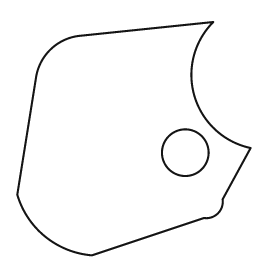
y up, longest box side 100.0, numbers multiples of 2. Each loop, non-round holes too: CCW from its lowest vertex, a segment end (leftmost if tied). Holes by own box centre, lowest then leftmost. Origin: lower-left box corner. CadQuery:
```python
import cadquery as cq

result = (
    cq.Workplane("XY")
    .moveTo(32.0, 0.0)
    .lineTo(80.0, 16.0)
    .threePointArc((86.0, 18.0), (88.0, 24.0))
    .lineTo(100.0, 46.0)
    .threePointArc((76.0, 68.0), (84.0, 100.0))
    .lineTo(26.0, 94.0)
    .threePointArc((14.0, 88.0), (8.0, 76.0))
    .lineTo(0.0, 26.0)
    .threePointArc((12.0, 8.0), (32.0, 0.0))
    .close()
    .moveTo(72.0, 44.0)
    .circle(10.0)
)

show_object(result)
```